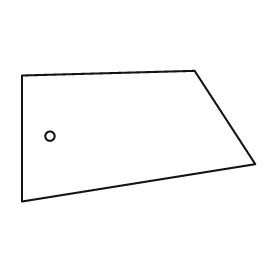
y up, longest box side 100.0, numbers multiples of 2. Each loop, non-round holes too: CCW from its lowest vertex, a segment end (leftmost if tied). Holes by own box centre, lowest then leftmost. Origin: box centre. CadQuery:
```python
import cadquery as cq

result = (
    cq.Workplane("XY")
    .moveTo(-50.0, -28.0)
    .lineTo(50.0, -12.0)
    .lineTo(24.0, 28.0)
    .lineTo(-50.0, 26.0)
    .close()
    .moveTo(-38.0, 0.0)
    .circle(2.0)
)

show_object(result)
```